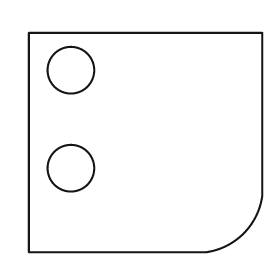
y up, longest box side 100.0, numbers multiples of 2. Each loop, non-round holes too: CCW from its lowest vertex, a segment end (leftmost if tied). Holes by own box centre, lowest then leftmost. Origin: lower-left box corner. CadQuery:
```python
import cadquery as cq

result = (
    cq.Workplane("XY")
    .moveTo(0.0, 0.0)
    .lineTo(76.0, 0.0)
    .threePointArc((92.0, 8.0), (100.0, 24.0))
    .lineTo(100.0, 94.0)
    .lineTo(0.0, 94.0)
    .close()
    .moveTo(18.0, 36.0)
    .circle(10.0)
    .moveTo(18.0, 78.0)
    .circle(10.0)
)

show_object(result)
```